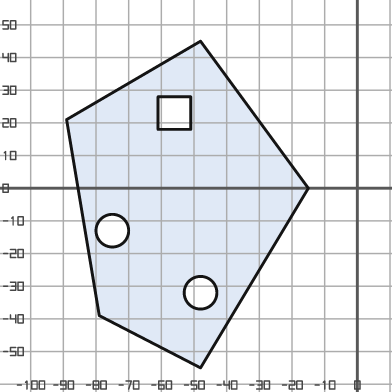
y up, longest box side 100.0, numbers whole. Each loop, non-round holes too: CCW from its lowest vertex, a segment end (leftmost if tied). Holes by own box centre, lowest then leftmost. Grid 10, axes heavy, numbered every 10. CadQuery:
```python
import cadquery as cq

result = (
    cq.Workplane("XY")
    .moveTo(-48.0, -55.0)
    .lineTo(-15.0, 0.0)
    .lineTo(-48.0, 45.0)
    .lineTo(-89.0, 21.0)
    .lineTo(-79.0, -39.0)
    .close()
    .moveTo(-48.0, -32.0)
    .circle(5.0)
    .moveTo(-75.0, -13.0)
    .circle(5.0)
    .moveTo(-61.0, 18.0)
    .lineTo(-51.0, 18.0)
    .lineTo(-51.0, 28.0)
    .lineTo(-61.0, 28.0)
    .close()
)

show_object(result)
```